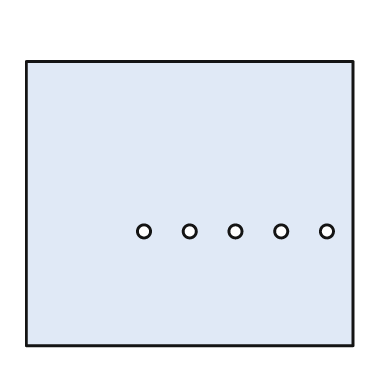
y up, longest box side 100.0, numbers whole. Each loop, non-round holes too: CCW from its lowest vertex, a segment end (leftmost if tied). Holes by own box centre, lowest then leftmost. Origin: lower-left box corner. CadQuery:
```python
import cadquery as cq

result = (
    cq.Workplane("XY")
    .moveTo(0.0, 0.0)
    .lineTo(100.0, 0.0)
    .lineTo(100.0, 87.0)
    .lineTo(0.0, 87.0)
    .close()
    .moveTo(36.0, 35.0)
    .circle(2.0)
    .moveTo(50.0, 35.0)
    .circle(2.0)
    .moveTo(64.0, 35.0)
    .circle(2.0)
    .moveTo(78.0, 35.0)
    .circle(2.0)
    .moveTo(92.0, 35.0)
    .circle(2.0)
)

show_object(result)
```